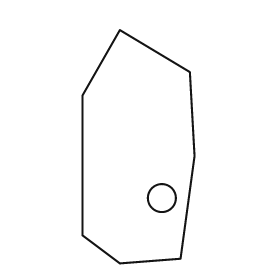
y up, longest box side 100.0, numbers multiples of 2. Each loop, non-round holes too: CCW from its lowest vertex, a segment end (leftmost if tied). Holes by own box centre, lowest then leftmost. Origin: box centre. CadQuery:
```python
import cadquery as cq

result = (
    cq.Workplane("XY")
    .moveTo(-8.0, -50.0)
    .lineTo(18.0, -48.0)
    .lineTo(24.0, -4.0)
    .lineTo(22.0, 32.0)
    .lineTo(-8.0, 50.0)
    .lineTo(-24.0, 22.0)
    .lineTo(-24.0, -38.0)
    .close()
    .moveTo(10.0, -22.0)
    .circle(6.0)
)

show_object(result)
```